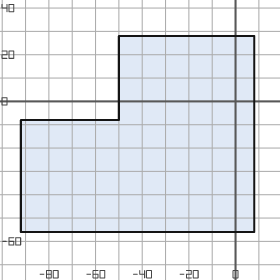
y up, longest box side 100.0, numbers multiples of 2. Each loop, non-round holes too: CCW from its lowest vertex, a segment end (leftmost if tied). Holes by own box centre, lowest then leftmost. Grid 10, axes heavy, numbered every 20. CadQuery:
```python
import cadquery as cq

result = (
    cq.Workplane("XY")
    .moveTo(-92.0, -56.0)
    .lineTo(8.0, -56.0)
    .lineTo(8.0, 28.0)
    .lineTo(-50.0, 28.0)
    .lineTo(-50.0, -8.0)
    .lineTo(-92.0, -8.0)
    .close()
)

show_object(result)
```